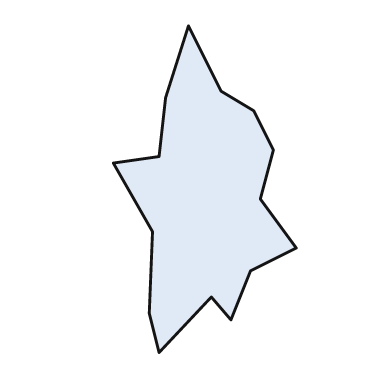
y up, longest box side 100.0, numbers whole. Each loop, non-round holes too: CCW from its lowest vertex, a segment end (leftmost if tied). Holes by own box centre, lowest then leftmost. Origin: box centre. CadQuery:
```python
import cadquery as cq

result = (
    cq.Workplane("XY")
    .moveTo(-14.0, -50.0)
    .lineTo(2.0, -33.0)
    .lineTo(8.0, -40.0)
    .lineTo(14.0, -25.0)
    .lineTo(28.0, -18.0)
    .lineTo(17.0, -3.0)
    .lineTo(21.0, 12.0)
    .lineTo(15.0, 24.0)
    .lineTo(5.0, 30.0)
    .lineTo(-5.0, 50.0)
    .lineTo(-12.0, 28.0)
    .lineTo(-14.0, 10.0)
    .lineTo(-28.0, 8.0)
    .lineTo(-16.0, -13.0)
    .lineTo(-17.0, -38.0)
    .close()
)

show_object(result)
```